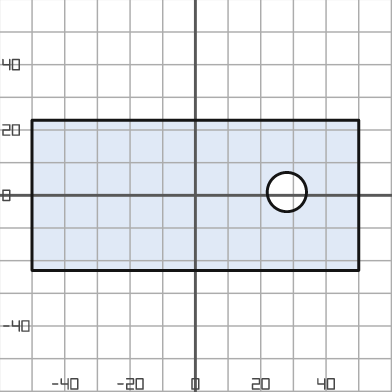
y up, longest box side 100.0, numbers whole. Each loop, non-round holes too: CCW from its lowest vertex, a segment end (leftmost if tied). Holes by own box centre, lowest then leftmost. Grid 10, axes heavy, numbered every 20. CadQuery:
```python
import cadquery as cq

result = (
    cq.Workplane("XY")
    .moveTo(-50.0, -23.0)
    .lineTo(50.0, -23.0)
    .lineTo(50.0, 23.0)
    .lineTo(-50.0, 23.0)
    .close()
    .moveTo(28.0, 1.0)
    .circle(6.0)
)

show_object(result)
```